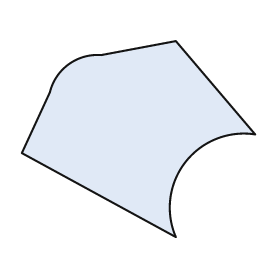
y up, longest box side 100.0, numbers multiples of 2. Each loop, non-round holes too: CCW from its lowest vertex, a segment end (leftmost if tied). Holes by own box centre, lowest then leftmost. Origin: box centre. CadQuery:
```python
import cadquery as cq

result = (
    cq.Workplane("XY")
    .moveTo(16.0, -42.0)
    .threePointArc((20.0, -10.0), (50.0, 2.0))
    .lineTo(16.0, 42.0)
    .lineTo(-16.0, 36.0)
    .threePointArc((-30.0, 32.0), (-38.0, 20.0))
    .lineTo(-50.0, -6.0)
    .close()
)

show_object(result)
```